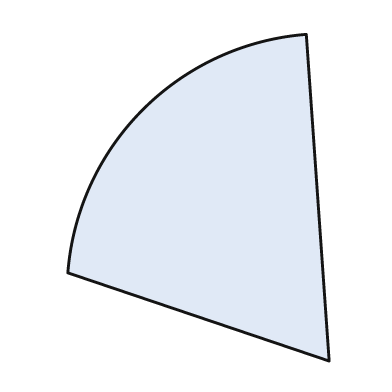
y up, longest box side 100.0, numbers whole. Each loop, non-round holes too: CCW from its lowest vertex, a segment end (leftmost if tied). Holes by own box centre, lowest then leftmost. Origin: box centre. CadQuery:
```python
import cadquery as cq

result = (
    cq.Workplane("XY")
    .moveTo(40.0, -50.0)
    .lineTo(33.0, 50.0)
    .threePointArc((-17.0, 27.0), (-40.0, -23.0))
    .close()
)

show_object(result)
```